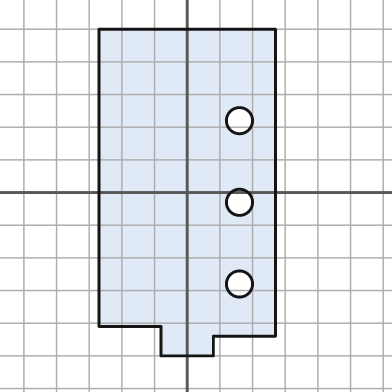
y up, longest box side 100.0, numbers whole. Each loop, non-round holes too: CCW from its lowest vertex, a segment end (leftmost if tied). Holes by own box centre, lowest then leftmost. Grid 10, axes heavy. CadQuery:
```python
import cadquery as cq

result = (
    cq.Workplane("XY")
    .moveTo(-8.0, -50.0)
    .lineTo(8.0, -50.0)
    .lineTo(8.0, -44.0)
    .lineTo(27.0, -44.0)
    .lineTo(27.0, 50.0)
    .lineTo(-27.0, 50.0)
    .lineTo(-27.0, -41.0)
    .lineTo(-8.0, -41.0)
    .close()
    .moveTo(16.0, -28.0)
    .circle(4.0)
    .moveTo(16.0, -3.0)
    .circle(4.0)
    .moveTo(16.0, 22.0)
    .circle(4.0)
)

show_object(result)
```